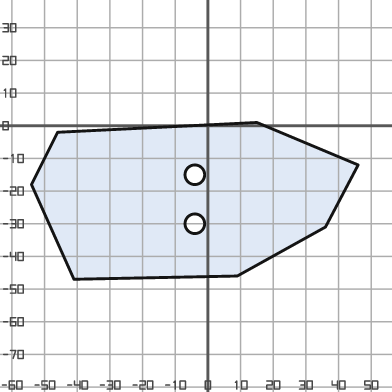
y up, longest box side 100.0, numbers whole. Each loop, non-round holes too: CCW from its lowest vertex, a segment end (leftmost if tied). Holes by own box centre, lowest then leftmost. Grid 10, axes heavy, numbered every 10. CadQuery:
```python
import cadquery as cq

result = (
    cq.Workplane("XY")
    .moveTo(-41.0, -47.0)
    .lineTo(9.0, -46.0)
    .lineTo(36.0, -31.0)
    .lineTo(46.0, -12.0)
    .lineTo(15.0, 1.0)
    .lineTo(-46.0, -2.0)
    .lineTo(-54.0, -18.0)
    .close()
    .moveTo(-4.0, -30.0)
    .circle(3.0)
    .moveTo(-4.0, -15.0)
    .circle(3.0)
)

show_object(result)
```